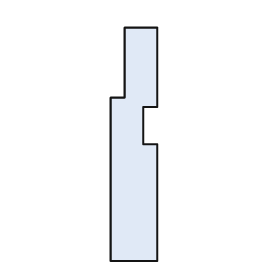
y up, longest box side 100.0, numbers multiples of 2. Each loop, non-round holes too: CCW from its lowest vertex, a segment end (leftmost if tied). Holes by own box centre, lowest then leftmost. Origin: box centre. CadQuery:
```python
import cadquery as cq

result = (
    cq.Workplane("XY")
    .moveTo(-10.0, -50.0)
    .lineTo(10.0, -50.0)
    .lineTo(10.0, 0.0)
    .lineTo(4.0, 0.0)
    .lineTo(4.0, 16.0)
    .lineTo(10.0, 16.0)
    .lineTo(10.0, 50.0)
    .lineTo(-4.0, 50.0)
    .lineTo(-4.0, 20.0)
    .lineTo(-10.0, 20.0)
    .close()
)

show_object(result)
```